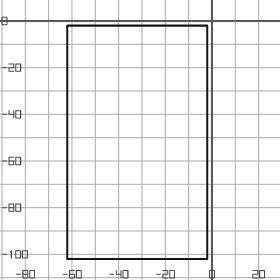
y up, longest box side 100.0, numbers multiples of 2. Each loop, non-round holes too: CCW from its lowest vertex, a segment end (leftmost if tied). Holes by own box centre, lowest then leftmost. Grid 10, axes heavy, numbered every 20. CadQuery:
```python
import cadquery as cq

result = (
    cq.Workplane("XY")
    .moveTo(-62.0, -102.0)
    .lineTo(-2.0, -102.0)
    .lineTo(-2.0, -2.0)
    .lineTo(-62.0, -2.0)
    .close()
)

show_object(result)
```